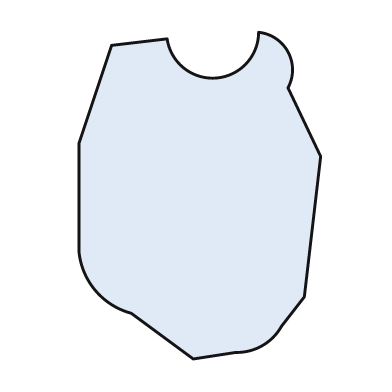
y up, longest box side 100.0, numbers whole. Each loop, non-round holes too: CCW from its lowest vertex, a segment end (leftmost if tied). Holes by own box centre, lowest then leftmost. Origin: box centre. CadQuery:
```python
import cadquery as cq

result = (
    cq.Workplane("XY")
    .moveTo(-2.0, -50.0)
    .lineTo(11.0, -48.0)
    .threePointArc((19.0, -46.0), (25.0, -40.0))
    .lineTo(32.0, -31.0)
    .lineTo(37.0, 12.0)
    .lineTo(27.0, 33.0)
    .threePointArc((27.0, 44.0), (18.0, 50.0))
    .threePointArc((5.0, 36.0), (-10.0, 48.0))
    .lineTo(-27.0, 46.0)
    .lineTo(-37.0, 16.0)
    .lineTo(-37.0, -17.0)
    .threePointArc((-32.0, -29.0), (-21.0, -36.0))
    .close()
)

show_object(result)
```